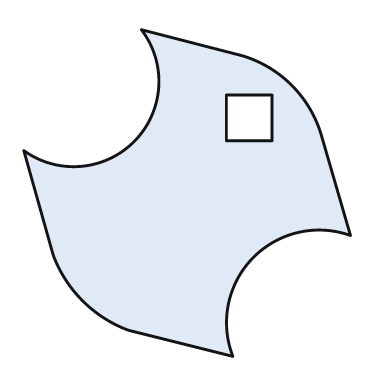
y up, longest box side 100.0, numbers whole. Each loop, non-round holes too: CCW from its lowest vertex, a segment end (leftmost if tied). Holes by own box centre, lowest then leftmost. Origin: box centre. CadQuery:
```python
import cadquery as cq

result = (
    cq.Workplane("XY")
    .moveTo(14.0, -50.0)
    .threePointArc((20.0, -20.0), (50.0, -13.0))
    .lineTo(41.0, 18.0)
    .threePointArc((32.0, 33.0), (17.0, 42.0))
    .lineTo(-14.0, 50.0)
    .threePointArc((-16.0, 16.0), (-50.0, 13.0))
    .lineTo(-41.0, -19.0)
    .threePointArc((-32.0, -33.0), (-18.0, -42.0))
    .close()
    .moveTo(12.0, 16.0)
    .lineTo(26.0, 16.0)
    .lineTo(26.0, 30.0)
    .lineTo(12.0, 30.0)
    .close()
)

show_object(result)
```